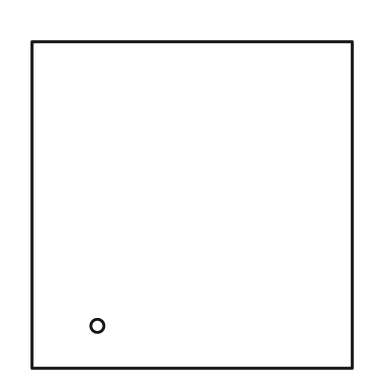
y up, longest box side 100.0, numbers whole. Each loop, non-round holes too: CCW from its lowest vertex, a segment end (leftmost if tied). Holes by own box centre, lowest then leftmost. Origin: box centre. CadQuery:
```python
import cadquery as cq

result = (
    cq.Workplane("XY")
    .moveTo(-49.0, -50.0)
    .lineTo(49.0, -50.0)
    .lineTo(49.0, 50.0)
    .lineTo(-49.0, 50.0)
    .close()
    .moveTo(-29.0, -37.0)
    .circle(2.0)
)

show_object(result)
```